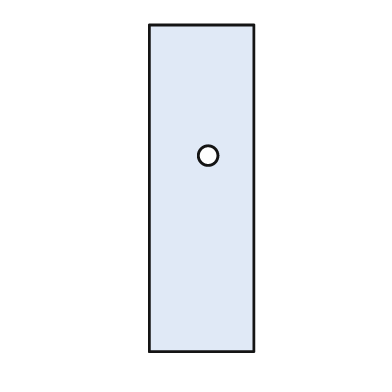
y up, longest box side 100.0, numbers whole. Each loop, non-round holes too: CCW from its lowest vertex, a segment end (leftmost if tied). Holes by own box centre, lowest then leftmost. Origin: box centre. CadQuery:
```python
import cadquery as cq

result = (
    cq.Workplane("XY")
    .moveTo(-16.0, -50.0)
    .lineTo(16.0, -50.0)
    .lineTo(16.0, 50.0)
    .lineTo(-16.0, 50.0)
    .close()
    .moveTo(2.0, 10.0)
    .circle(3.0)
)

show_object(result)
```